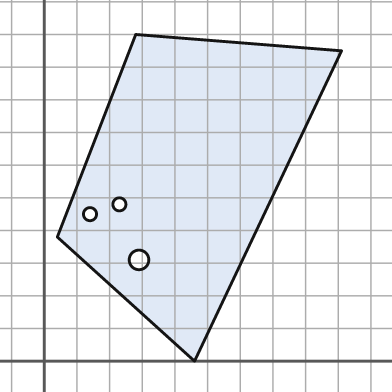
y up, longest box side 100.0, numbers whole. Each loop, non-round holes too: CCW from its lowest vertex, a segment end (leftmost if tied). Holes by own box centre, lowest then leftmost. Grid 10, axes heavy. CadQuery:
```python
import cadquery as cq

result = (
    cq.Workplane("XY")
    .moveTo(46.0, 0.0)
    .lineTo(91.0, 95.0)
    .lineTo(28.0, 100.0)
    .lineTo(4.0, 38.0)
    .close()
    .moveTo(29.0, 31.0)
    .circle(3.0)
    .moveTo(14.0, 45.0)
    .circle(2.0)
    .moveTo(23.0, 48.0)
    .circle(2.0)
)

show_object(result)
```